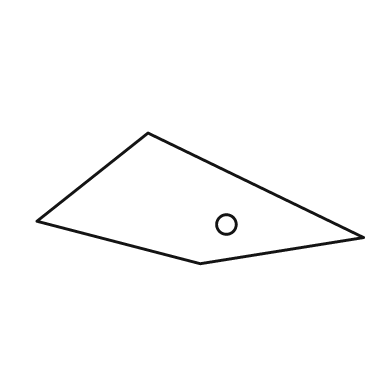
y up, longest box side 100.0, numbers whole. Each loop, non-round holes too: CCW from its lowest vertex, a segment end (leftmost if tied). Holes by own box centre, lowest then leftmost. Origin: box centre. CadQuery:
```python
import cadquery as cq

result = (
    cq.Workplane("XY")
    .moveTo(0.0, -20.0)
    .lineTo(50.0, -12.0)
    .lineTo(-16.0, 20.0)
    .lineTo(-50.0, -7.0)
    .close()
    .moveTo(8.0, -8.0)
    .circle(3.0)
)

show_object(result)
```